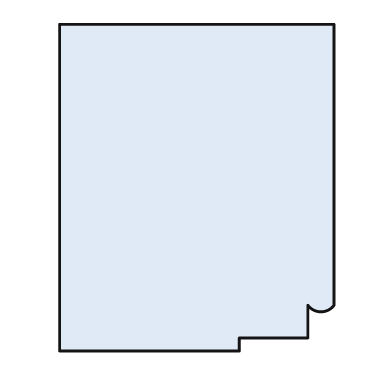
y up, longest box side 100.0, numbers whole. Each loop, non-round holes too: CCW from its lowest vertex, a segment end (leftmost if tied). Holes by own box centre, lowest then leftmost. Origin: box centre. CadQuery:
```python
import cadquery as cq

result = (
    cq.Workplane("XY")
    .moveTo(-42.0, -50.0)
    .lineTo(13.0, -50.0)
    .lineTo(13.0, -46.0)
    .lineTo(34.0, -46.0)
    .lineTo(34.0, -36.0)
    .threePointArc((38.0, -38.0), (42.0, -36.0))
    .lineTo(42.0, 50.0)
    .lineTo(-42.0, 50.0)
    .close()
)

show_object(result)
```